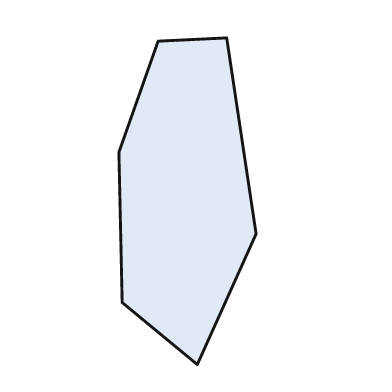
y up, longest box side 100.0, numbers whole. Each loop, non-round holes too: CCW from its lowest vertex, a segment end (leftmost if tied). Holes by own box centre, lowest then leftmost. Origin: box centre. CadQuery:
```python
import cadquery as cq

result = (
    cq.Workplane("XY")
    .moveTo(3.0, -50.0)
    .lineTo(21.0, -10.0)
    .lineTo(12.0, 50.0)
    .lineTo(-9.0, 49.0)
    .lineTo(-21.0, 15.0)
    .lineTo(-20.0, -31.0)
    .close()
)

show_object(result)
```